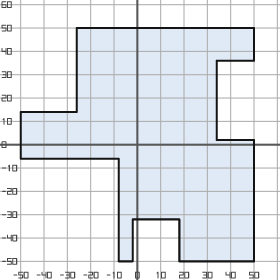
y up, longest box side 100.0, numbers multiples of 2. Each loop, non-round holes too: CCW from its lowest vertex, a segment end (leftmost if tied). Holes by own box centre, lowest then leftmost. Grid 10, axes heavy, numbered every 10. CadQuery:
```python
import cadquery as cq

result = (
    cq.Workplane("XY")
    .moveTo(-8.0, -50.0)
    .lineTo(-2.0, -50.0)
    .lineTo(-2.0, -32.0)
    .lineTo(18.0, -32.0)
    .lineTo(18.0, -50.0)
    .lineTo(50.0, -50.0)
    .lineTo(50.0, 2.0)
    .lineTo(34.0, 2.0)
    .lineTo(34.0, 36.0)
    .lineTo(50.0, 36.0)
    .lineTo(50.0, 50.0)
    .lineTo(-26.0, 50.0)
    .lineTo(-26.0, 14.0)
    .lineTo(-50.0, 14.0)
    .lineTo(-50.0, -6.0)
    .lineTo(-8.0, -6.0)
    .close()
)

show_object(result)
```